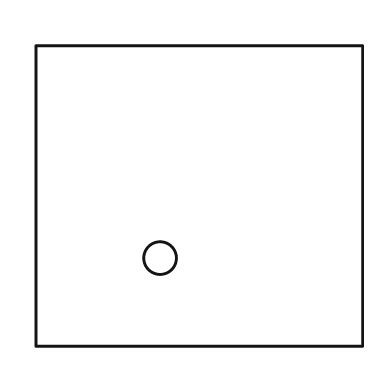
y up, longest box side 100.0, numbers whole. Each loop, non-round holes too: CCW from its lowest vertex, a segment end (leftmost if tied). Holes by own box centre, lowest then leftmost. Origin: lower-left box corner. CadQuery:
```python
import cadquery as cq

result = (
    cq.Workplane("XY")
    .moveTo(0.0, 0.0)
    .lineTo(100.0, 0.0)
    .lineTo(100.0, 92.0)
    .lineTo(0.0, 92.0)
    .close()
    .moveTo(38.0, 27.0)
    .circle(5.0)
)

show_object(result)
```